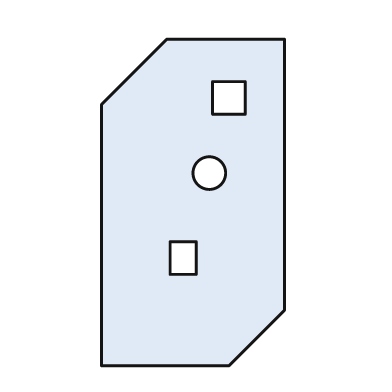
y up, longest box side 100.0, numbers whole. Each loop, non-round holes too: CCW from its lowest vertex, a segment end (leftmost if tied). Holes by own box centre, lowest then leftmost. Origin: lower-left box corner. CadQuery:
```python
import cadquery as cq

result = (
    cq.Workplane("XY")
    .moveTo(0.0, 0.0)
    .lineTo(39.0, 0.0)
    .lineTo(56.0, 17.0)
    .lineTo(56.0, 100.0)
    .lineTo(20.0, 100.0)
    .lineTo(0.0, 80.0)
    .close()
    .moveTo(21.0, 28.0)
    .lineTo(29.0, 28.0)
    .lineTo(29.0, 38.0)
    .lineTo(21.0, 38.0)
    .close()
    .moveTo(33.0, 59.0)
    .circle(5.0)
    .moveTo(34.0, 77.0)
    .lineTo(44.0, 77.0)
    .lineTo(44.0, 87.0)
    .lineTo(34.0, 87.0)
    .close()
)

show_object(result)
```